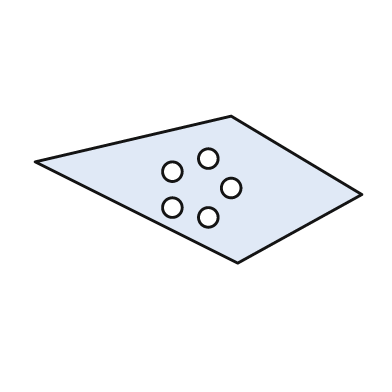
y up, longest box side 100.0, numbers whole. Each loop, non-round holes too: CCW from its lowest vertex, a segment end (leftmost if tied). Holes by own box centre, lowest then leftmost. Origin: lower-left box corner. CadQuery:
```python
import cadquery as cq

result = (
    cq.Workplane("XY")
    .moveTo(62.0, 0.0)
    .lineTo(100.0, 21.0)
    .lineTo(60.0, 45.0)
    .lineTo(0.0, 31.0)
    .close()
    .moveTo(53.0, 14.0)
    .circle(3.0)
    .moveTo(42.0, 17.0)
    .circle(3.0)
    .moveTo(60.0, 23.0)
    .circle(3.0)
    .moveTo(42.0, 28.0)
    .circle(3.0)
    .moveTo(53.0, 32.0)
    .circle(3.0)
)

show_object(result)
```